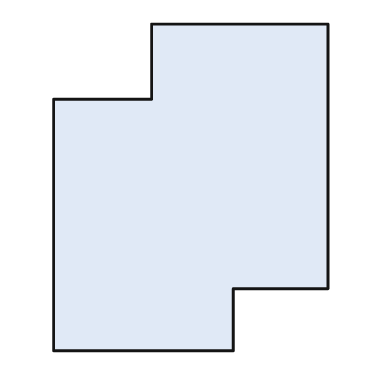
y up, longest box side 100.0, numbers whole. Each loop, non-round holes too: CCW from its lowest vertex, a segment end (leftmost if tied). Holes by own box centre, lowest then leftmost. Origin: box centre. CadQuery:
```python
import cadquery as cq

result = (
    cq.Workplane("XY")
    .moveTo(-42.0, -50.0)
    .lineTo(13.0, -50.0)
    .lineTo(13.0, -31.0)
    .lineTo(42.0, -31.0)
    .lineTo(42.0, 50.0)
    .lineTo(-12.0, 50.0)
    .lineTo(-12.0, 27.0)
    .lineTo(-42.0, 27.0)
    .close()
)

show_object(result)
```